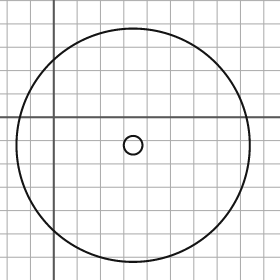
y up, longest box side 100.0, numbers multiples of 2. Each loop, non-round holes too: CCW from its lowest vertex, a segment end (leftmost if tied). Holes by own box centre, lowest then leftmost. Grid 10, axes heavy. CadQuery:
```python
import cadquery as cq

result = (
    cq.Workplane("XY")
    .moveTo(34.0, -12.0)
    .circle(50.0)
    .moveTo(34.0, -12.0)
    .circle(4.0)
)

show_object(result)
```